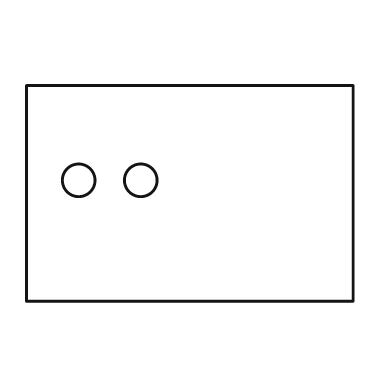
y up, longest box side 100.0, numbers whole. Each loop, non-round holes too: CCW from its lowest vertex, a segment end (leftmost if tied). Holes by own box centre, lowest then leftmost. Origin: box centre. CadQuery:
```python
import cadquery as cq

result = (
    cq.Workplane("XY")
    .moveTo(-50.0, -33.0)
    .lineTo(50.0, -33.0)
    .lineTo(50.0, 33.0)
    .lineTo(-50.0, 33.0)
    .close()
    .moveTo(-34.0, 4.0)
    .circle(5.0)
    .moveTo(-15.0, 4.0)
    .circle(5.0)
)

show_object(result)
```